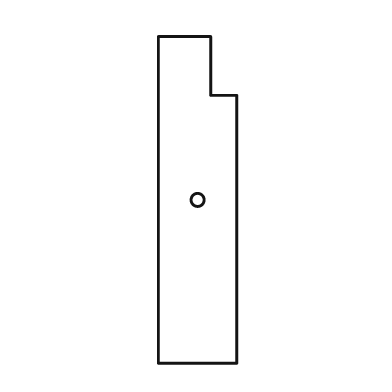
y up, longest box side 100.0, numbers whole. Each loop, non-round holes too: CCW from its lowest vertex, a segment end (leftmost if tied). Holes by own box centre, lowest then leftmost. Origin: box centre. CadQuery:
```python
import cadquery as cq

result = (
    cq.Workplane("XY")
    .moveTo(-12.0, -50.0)
    .lineTo(12.0, -50.0)
    .lineTo(12.0, 32.0)
    .lineTo(4.0, 32.0)
    .lineTo(4.0, 50.0)
    .lineTo(-12.0, 50.0)
    .close()
    .moveTo(0.0, 0.0)
    .circle(2.0)
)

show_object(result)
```